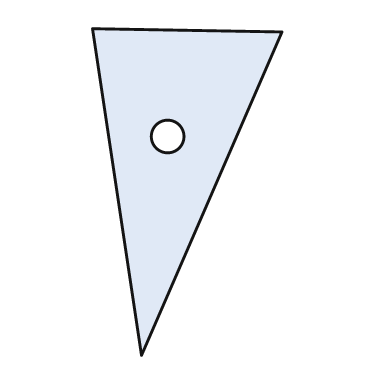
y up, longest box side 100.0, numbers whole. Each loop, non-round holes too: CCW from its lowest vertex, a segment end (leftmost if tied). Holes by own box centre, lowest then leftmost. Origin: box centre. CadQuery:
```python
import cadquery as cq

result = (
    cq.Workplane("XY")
    .moveTo(-14.0, -50.0)
    .lineTo(29.0, 49.0)
    .lineTo(-29.0, 50.0)
    .close()
    .moveTo(-6.0, 17.0)
    .circle(5.0)
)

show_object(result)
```